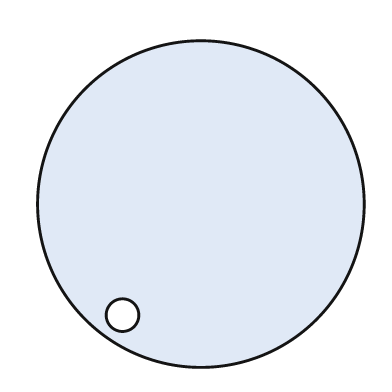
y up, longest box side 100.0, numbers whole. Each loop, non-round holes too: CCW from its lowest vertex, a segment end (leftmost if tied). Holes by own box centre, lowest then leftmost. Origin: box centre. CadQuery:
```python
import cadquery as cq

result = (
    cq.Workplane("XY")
    .moveTo(0.0, 0.0)
    .circle(50.0)
    .moveTo(-24.0, -34.0)
    .circle(5.0)
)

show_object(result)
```